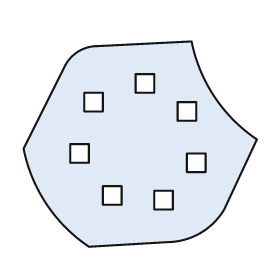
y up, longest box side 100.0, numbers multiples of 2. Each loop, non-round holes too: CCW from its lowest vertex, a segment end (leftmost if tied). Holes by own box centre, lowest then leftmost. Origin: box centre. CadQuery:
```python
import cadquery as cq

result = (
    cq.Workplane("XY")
    .moveTo(-22.0, -44.0)
    .lineTo(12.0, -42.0)
    .threePointArc((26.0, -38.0), (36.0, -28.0))
    .lineTo(50.0, 2.0)
    .threePointArc((32.0, 20.0), (22.0, 44.0))
    .lineTo(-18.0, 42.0)
    .threePointArc((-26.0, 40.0), (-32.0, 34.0))
    .lineTo(-50.0, -2.0)
    .threePointArc((-40.0, -26.0), (-22.0, -44.0))
    .close()
    .moveTo(6.0, -28.0)
    .lineTo(14.0, -28.0)
    .lineTo(14.0, -20.0)
    .lineTo(6.0, -20.0)
    .close()
    .moveTo(-16.0, -26.0)
    .lineTo(-8.0, -26.0)
    .lineTo(-8.0, -18.0)
    .lineTo(-16.0, -18.0)
    .close()
    .moveTo(20.0, -12.0)
    .lineTo(28.0, -12.0)
    .lineTo(28.0, -4.0)
    .lineTo(20.0, -4.0)
    .close()
    .moveTo(-30.0, -8.0)
    .lineTo(-22.0, -8.0)
    .lineTo(-22.0, 0.0)
    .lineTo(-30.0, 0.0)
    .close()
    .moveTo(16.0, 10.0)
    .lineTo(24.0, 10.0)
    .lineTo(24.0, 18.0)
    .lineTo(16.0, 18.0)
    .close()
    .moveTo(-24.0, 14.0)
    .lineTo(-16.0, 14.0)
    .lineTo(-16.0, 22.0)
    .lineTo(-24.0, 22.0)
    .close()
    .moveTo(-2.0, 22.0)
    .lineTo(6.0, 22.0)
    .lineTo(6.0, 30.0)
    .lineTo(-2.0, 30.0)
    .close()
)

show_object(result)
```